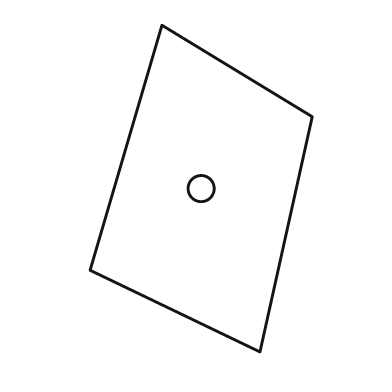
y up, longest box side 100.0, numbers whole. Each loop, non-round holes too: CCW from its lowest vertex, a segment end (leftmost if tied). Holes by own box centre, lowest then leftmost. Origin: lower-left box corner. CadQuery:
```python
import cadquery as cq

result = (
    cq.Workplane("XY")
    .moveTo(52.0, 0.0)
    .lineTo(68.0, 72.0)
    .lineTo(22.0, 100.0)
    .lineTo(0.0, 25.0)
    .close()
    .moveTo(34.0, 50.0)
    .circle(4.0)
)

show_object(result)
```